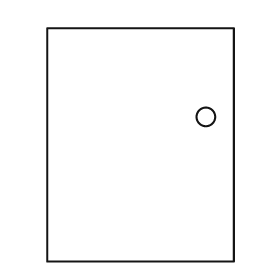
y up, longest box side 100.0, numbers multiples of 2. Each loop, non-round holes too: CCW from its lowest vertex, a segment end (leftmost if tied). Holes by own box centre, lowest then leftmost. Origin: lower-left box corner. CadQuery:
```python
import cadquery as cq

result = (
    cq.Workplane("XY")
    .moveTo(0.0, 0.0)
    .lineTo(80.0, 0.0)
    .lineTo(80.0, 100.0)
    .lineTo(0.0, 100.0)
    .close()
    .moveTo(68.0, 62.0)
    .circle(4.0)
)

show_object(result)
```